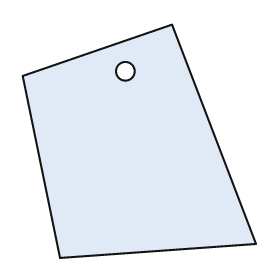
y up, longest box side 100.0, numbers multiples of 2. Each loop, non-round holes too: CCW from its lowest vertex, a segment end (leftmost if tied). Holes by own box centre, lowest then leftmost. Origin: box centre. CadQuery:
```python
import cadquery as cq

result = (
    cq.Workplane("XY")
    .moveTo(-34.0, -50.0)
    .lineTo(50.0, -44.0)
    .lineTo(14.0, 50.0)
    .lineTo(-50.0, 28.0)
    .close()
    .moveTo(-6.0, 30.0)
    .circle(4.0)
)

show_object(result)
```